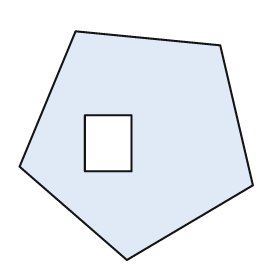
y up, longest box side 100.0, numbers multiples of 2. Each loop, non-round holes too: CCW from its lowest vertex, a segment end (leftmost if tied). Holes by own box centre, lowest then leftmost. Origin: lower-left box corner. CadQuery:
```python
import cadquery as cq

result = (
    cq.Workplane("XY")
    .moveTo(46.0, 0.0)
    .lineTo(100.0, 32.0)
    .lineTo(86.0, 92.0)
    .lineTo(24.0, 98.0)
    .lineTo(0.0, 40.0)
    .close()
    .moveTo(28.0, 38.0)
    .lineTo(48.0, 38.0)
    .lineTo(48.0, 62.0)
    .lineTo(28.0, 62.0)
    .close()
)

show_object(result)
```